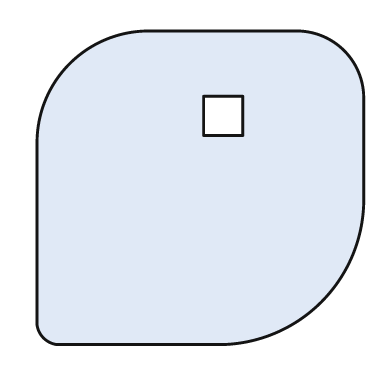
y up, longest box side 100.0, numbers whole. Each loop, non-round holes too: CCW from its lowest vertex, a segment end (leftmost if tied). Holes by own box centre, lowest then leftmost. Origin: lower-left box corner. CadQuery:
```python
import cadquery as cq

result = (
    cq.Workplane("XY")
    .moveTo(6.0, 0.0)
    .lineTo(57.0, 0.0)
    .threePointArc((87.0, 13.0), (100.0, 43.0))
    .lineTo(100.0, 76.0)
    .threePointArc((94.0, 90.0), (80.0, 96.0))
    .lineTo(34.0, 96.0)
    .threePointArc((10.0, 86.0), (0.0, 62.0))
    .lineTo(0.0, 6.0)
    .threePointArc((2.0, 2.0), (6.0, 0.0))
    .close()
    .moveTo(51.0, 64.0)
    .lineTo(63.0, 64.0)
    .lineTo(63.0, 76.0)
    .lineTo(51.0, 76.0)
    .close()
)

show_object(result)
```